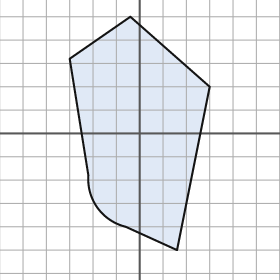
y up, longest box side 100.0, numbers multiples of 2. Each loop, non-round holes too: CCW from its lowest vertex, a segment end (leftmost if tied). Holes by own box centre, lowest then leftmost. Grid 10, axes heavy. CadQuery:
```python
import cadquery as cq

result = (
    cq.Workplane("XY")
    .moveTo(16.0, -50.0)
    .lineTo(30.0, 20.0)
    .lineTo(-4.0, 50.0)
    .lineTo(-30.0, 32.0)
    .lineTo(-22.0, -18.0)
    .threePointArc((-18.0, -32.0), (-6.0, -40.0))
    .close()
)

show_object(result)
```